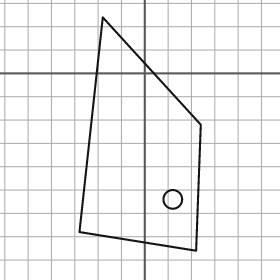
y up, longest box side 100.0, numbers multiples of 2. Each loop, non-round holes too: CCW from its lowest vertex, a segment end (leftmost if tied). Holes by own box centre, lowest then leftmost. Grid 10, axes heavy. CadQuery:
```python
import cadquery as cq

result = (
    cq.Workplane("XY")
    .moveTo(22.0, -76.0)
    .lineTo(24.0, -22.0)
    .lineTo(-18.0, 24.0)
    .lineTo(-28.0, -68.0)
    .close()
    .moveTo(12.0, -54.0)
    .circle(4.0)
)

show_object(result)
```